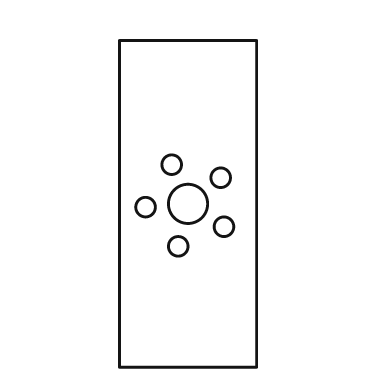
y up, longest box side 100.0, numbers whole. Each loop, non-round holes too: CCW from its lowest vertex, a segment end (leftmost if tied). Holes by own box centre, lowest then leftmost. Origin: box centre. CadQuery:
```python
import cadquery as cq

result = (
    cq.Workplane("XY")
    .moveTo(-21.0, -50.0)
    .lineTo(21.0, -50.0)
    .lineTo(21.0, 50.0)
    .lineTo(-21.0, 50.0)
    .close()
    .moveTo(-3.0, -13.0)
    .circle(3.0)
    .moveTo(11.0, -7.0)
    .circle(3.0)
    .moveTo(-13.0, -1.0)
    .circle(3.0)
    .moveTo(0.0, 0.0)
    .circle(6.0)
    .moveTo(10.0, 8.0)
    .circle(3.0)
    .moveTo(-5.0, 12.0)
    .circle(3.0)
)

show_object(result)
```